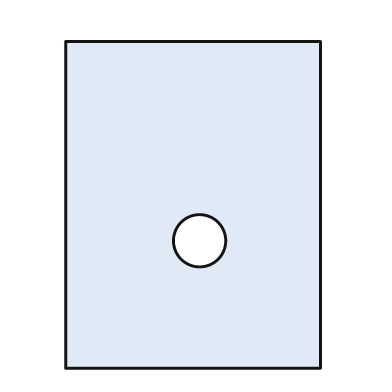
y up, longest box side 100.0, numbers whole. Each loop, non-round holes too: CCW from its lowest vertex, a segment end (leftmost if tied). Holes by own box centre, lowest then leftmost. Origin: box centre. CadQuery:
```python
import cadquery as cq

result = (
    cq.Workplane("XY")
    .moveTo(-39.0, -50.0)
    .lineTo(39.0, -50.0)
    .lineTo(39.0, 50.0)
    .lineTo(-39.0, 50.0)
    .close()
    .moveTo(2.0, -11.0)
    .circle(8.0)
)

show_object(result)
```